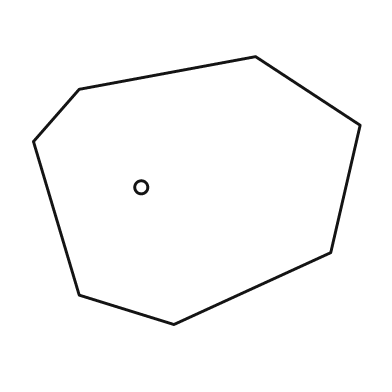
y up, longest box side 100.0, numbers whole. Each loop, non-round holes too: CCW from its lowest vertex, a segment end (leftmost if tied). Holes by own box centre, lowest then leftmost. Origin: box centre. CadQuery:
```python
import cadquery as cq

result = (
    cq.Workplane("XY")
    .moveTo(-7.0, -41.0)
    .lineTo(41.0, -19.0)
    .lineTo(50.0, 20.0)
    .lineTo(18.0, 41.0)
    .lineTo(-36.0, 31.0)
    .lineTo(-50.0, 15.0)
    .lineTo(-36.0, -32.0)
    .close()
    .moveTo(-17.0, 1.0)
    .circle(2.0)
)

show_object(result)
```